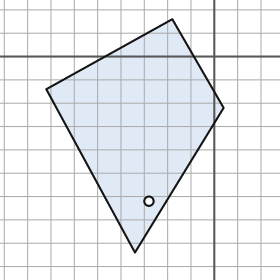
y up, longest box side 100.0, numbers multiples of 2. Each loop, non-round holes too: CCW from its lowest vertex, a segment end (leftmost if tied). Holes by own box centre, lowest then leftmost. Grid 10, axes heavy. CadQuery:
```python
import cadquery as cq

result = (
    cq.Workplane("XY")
    .moveTo(-34.0, -84.0)
    .lineTo(4.0, -22.0)
    .lineTo(-18.0, 16.0)
    .lineTo(-72.0, -14.0)
    .close()
    .moveTo(-28.0, -62.0)
    .circle(2.0)
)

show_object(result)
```